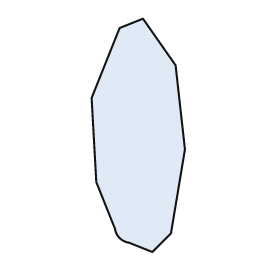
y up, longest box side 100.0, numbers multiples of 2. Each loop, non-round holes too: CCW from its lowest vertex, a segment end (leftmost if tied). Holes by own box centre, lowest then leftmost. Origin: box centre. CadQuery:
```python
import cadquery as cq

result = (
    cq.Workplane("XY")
    .moveTo(6.0, -50.0)
    .lineTo(14.0, -42.0)
    .lineTo(20.0, -6.0)
    .lineTo(16.0, 30.0)
    .lineTo(2.0, 50.0)
    .lineTo(-8.0, 46.0)
    .lineTo(-20.0, 16.0)
    .lineTo(-18.0, -20.0)
    .lineTo(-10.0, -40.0)
    .threePointArc((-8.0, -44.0), (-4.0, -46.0))
    .close()
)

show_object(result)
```